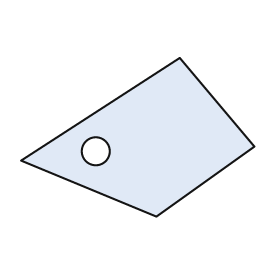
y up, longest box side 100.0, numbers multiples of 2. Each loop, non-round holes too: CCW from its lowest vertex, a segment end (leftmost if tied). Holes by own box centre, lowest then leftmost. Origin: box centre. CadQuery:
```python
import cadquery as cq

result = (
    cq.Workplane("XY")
    .moveTo(8.0, -34.0)
    .lineTo(50.0, -4.0)
    .lineTo(18.0, 34.0)
    .lineTo(-50.0, -10.0)
    .close()
    .moveTo(-18.0, -6.0)
    .circle(6.0)
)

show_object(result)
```